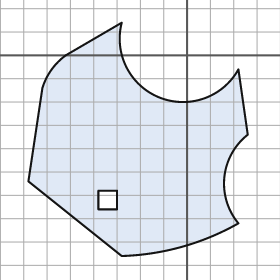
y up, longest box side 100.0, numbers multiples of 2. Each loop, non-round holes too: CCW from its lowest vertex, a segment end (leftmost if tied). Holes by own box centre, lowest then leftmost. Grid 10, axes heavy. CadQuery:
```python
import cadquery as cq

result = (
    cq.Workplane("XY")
    .moveTo(-28.0, -86.0)
    .threePointArc((-2.0, -82.0), (22.0, -72.0))
    .threePointArc((16.0, -52.0), (26.0, -34.0))
    .lineTo(22.0, -6.0)
    .threePointArc((-12.0, -18.0), (-28.0, 14.0))
    .lineTo(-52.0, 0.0)
    .threePointArc((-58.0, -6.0), (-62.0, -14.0))
    .lineTo(-68.0, -54.0)
    .close()
    .moveTo(-38.0, -66.0)
    .lineTo(-30.0, -66.0)
    .lineTo(-30.0, -58.0)
    .lineTo(-38.0, -58.0)
    .close()
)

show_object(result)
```